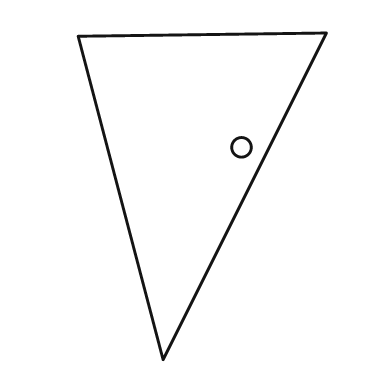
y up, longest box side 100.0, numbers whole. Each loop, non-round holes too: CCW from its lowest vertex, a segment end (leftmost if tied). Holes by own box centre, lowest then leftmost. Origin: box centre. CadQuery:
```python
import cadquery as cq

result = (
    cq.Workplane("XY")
    .moveTo(-12.0, -50.0)
    .lineTo(38.0, 50.0)
    .lineTo(-38.0, 49.0)
    .close()
    .moveTo(12.0, 15.0)
    .circle(3.0)
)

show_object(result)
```